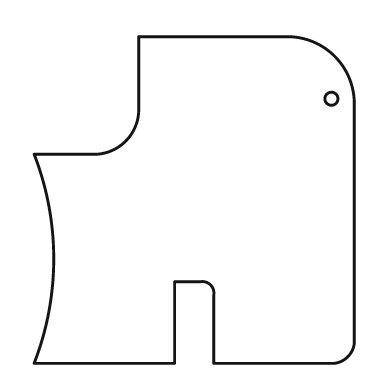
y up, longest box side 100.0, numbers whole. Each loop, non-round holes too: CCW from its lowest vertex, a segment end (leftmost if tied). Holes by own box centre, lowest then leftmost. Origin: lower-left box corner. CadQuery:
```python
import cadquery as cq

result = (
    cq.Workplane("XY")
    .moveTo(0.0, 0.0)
    .lineTo(43.0, 0.0)
    .lineTo(43.0, 25.0)
    .lineTo(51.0, 25.0)
    .threePointArc((54.0, 24.0), (55.0, 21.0))
    .lineTo(55.0, 0.0)
    .lineTo(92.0, 0.0)
    .threePointArc((96.0, 2.0), (98.0, 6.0))
    .lineTo(98.0, 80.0)
    .threePointArc((92.0, 94.0), (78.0, 100.0))
    .lineTo(32.0, 100.0)
    .lineTo(32.0, 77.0)
    .threePointArc((28.0, 68.0), (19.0, 64.0))
    .lineTo(0.0, 64.0)
    .threePointArc((6.0, 32.0), (0.0, 0.0))
    .close()
    .moveTo(91.0, 81.0)
    .circle(2.0)
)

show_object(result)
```